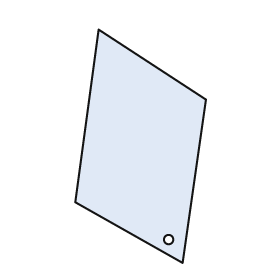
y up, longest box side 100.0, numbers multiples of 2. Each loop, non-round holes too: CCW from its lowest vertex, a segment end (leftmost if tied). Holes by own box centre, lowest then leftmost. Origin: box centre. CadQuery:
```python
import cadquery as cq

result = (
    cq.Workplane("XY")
    .moveTo(18.0, -50.0)
    .lineTo(28.0, 20.0)
    .lineTo(-18.0, 50.0)
    .lineTo(-28.0, -24.0)
    .close()
    .moveTo(12.0, -40.0)
    .circle(2.0)
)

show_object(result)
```